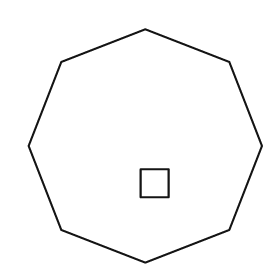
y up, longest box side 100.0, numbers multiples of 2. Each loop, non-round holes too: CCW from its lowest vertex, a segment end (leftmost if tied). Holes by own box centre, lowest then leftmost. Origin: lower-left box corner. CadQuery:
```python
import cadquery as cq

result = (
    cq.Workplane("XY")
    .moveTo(50.0, 0.0)
    .lineTo(86.0, 14.0)
    .lineTo(100.0, 50.0)
    .lineTo(86.0, 86.0)
    .lineTo(50.0, 100.0)
    .lineTo(14.0, 86.0)
    .lineTo(0.0, 50.0)
    .lineTo(14.0, 14.0)
    .close()
    .moveTo(48.0, 28.0)
    .lineTo(60.0, 28.0)
    .lineTo(60.0, 40.0)
    .lineTo(48.0, 40.0)
    .close()
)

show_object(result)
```